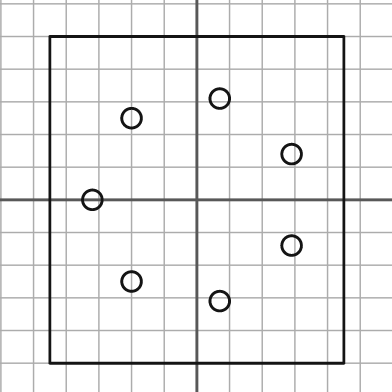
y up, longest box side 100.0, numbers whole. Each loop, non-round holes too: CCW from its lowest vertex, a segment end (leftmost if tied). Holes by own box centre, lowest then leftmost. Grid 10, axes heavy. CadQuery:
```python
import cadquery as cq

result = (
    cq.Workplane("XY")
    .moveTo(-45.0, -50.0)
    .lineTo(45.0, -50.0)
    .lineTo(45.0, 50.0)
    .lineTo(-45.0, 50.0)
    .close()
    .moveTo(7.0, -31.0)
    .circle(3.0)
    .moveTo(-20.0, -25.0)
    .circle(3.0)
    .moveTo(29.0, -14.0)
    .circle(3.0)
    .moveTo(-32.0, 0.0)
    .circle(3.0)
    .moveTo(29.0, 14.0)
    .circle(3.0)
    .moveTo(-20.0, 25.0)
    .circle(3.0)
    .moveTo(7.0, 31.0)
    .circle(3.0)
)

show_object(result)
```